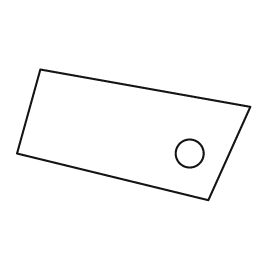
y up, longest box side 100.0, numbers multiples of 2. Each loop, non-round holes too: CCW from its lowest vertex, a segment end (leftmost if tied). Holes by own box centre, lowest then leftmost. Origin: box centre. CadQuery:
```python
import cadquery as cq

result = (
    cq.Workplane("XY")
    .moveTo(32.0, -28.0)
    .lineTo(50.0, 12.0)
    .lineTo(-40.0, 28.0)
    .lineTo(-50.0, -8.0)
    .close()
    .moveTo(24.0, -8.0)
    .circle(6.0)
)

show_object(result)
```